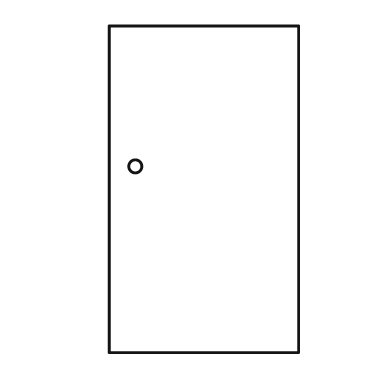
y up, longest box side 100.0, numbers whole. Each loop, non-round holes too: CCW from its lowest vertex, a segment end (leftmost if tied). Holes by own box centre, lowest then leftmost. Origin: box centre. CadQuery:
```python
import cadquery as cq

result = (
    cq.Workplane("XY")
    .moveTo(-29.0, -50.0)
    .lineTo(29.0, -50.0)
    .lineTo(29.0, 50.0)
    .lineTo(-29.0, 50.0)
    .close()
    .moveTo(-21.0, 7.0)
    .circle(2.0)
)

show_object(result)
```